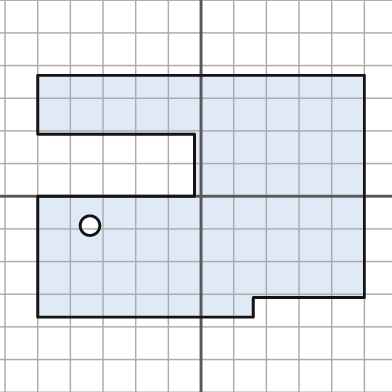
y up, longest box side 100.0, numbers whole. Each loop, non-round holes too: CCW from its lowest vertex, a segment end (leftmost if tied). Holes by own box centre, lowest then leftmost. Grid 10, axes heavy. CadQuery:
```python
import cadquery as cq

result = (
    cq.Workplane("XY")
    .moveTo(-50.0, -37.0)
    .lineTo(16.0, -37.0)
    .lineTo(16.0, -31.0)
    .lineTo(50.0, -31.0)
    .lineTo(50.0, 37.0)
    .lineTo(-50.0, 37.0)
    .lineTo(-50.0, 19.0)
    .lineTo(-2.0, 19.0)
    .lineTo(-2.0, 0.0)
    .lineTo(-50.0, 0.0)
    .close()
    .moveTo(-34.0, -9.0)
    .circle(3.0)
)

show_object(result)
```